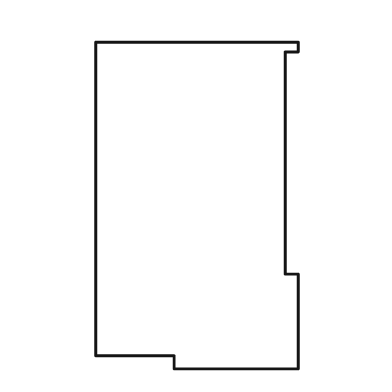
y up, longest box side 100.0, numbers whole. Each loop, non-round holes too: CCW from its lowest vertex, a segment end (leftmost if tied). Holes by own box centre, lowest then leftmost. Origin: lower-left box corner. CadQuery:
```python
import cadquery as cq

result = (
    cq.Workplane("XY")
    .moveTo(24.0, 0.0)
    .lineTo(62.0, 0.0)
    .lineTo(62.0, 29.0)
    .lineTo(58.0, 29.0)
    .lineTo(58.0, 97.0)
    .lineTo(62.0, 97.0)
    .lineTo(62.0, 100.0)
    .lineTo(0.0, 100.0)
    .lineTo(0.0, 4.0)
    .lineTo(24.0, 4.0)
    .close()
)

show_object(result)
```